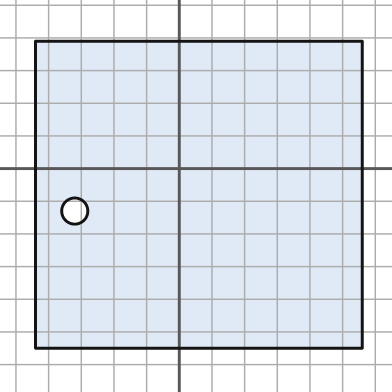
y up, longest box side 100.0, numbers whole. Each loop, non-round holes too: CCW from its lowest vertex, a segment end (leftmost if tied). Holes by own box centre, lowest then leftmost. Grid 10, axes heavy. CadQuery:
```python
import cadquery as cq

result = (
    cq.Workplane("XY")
    .moveTo(-44.0, -55.0)
    .lineTo(56.0, -55.0)
    .lineTo(56.0, 39.0)
    .lineTo(-44.0, 39.0)
    .close()
    .moveTo(-32.0, -13.0)
    .circle(4.0)
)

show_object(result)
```